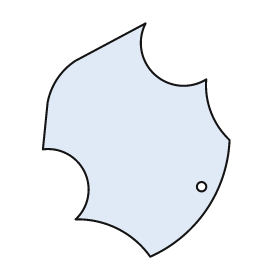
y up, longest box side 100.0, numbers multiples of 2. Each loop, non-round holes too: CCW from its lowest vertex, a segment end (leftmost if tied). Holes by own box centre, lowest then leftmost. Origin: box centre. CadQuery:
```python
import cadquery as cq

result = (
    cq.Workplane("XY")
    .moveTo(6.0, -50.0)
    .threePointArc((30.0, -30.0), (40.0, 0.0))
    .threePointArc((32.0, 12.0), (30.0, 26.0))
    .threePointArc((8.0, 28.0), (4.0, 50.0))
    .lineTo(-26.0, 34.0)
    .threePointArc((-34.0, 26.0), (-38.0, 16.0))
    .lineTo(-40.0, -4.0)
    .threePointArc((-22.0, -14.0), (-26.0, -34.0))
    .threePointArc((-8.0, -38.0), (6.0, -50.0))
    .close()
    .moveTo(28.0, -20.0)
    .circle(2.0)
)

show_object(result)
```